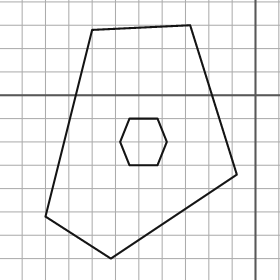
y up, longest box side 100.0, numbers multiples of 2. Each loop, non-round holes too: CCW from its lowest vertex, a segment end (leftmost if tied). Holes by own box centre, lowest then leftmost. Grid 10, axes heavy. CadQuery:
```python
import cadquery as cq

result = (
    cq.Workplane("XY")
    .moveTo(-62.0, -70.0)
    .lineTo(-8.0, -34.0)
    .lineTo(-28.0, 30.0)
    .lineTo(-70.0, 28.0)
    .lineTo(-90.0, -52.0)
    .close()
    .moveTo(-54.0, -30.0)
    .lineTo(-42.0, -30.0)
    .lineTo(-38.0, -20.0)
    .lineTo(-42.0, -10.0)
    .lineTo(-54.0, -10.0)
    .lineTo(-58.0, -20.0)
    .close()
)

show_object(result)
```